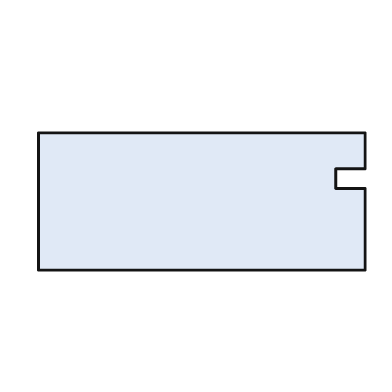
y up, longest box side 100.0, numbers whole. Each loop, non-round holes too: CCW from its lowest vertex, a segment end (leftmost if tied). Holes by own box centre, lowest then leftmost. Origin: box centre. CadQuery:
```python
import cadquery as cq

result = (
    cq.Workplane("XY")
    .moveTo(-50.0, -21.0)
    .lineTo(50.0, -21.0)
    .lineTo(50.0, 4.0)
    .lineTo(41.0, 4.0)
    .lineTo(41.0, 10.0)
    .lineTo(50.0, 10.0)
    .lineTo(50.0, 21.0)
    .lineTo(-50.0, 21.0)
    .close()
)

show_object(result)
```